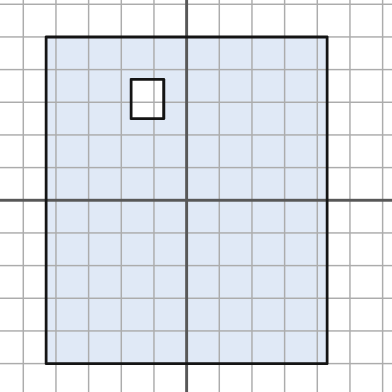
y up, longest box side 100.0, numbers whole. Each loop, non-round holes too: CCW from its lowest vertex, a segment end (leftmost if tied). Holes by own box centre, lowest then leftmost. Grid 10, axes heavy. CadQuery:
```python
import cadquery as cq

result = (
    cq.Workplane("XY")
    .moveTo(-43.0, -50.0)
    .lineTo(43.0, -50.0)
    .lineTo(43.0, 50.0)
    .lineTo(-43.0, 50.0)
    .close()
    .moveTo(-17.0, 25.0)
    .lineTo(-7.0, 25.0)
    .lineTo(-7.0, 37.0)
    .lineTo(-17.0, 37.0)
    .close()
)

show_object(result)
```